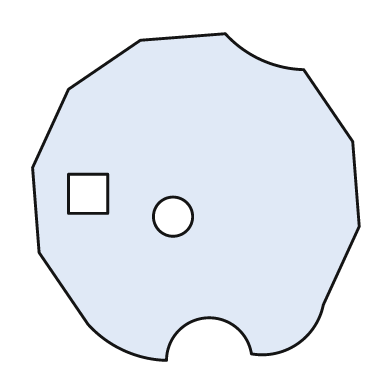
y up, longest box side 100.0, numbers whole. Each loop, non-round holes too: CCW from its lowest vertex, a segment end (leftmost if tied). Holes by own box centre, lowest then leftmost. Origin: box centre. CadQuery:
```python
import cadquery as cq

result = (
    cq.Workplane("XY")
    .moveTo(-9.0, -50.0)
    .threePointArc((3.0, -37.0), (17.0, -48.0))
    .threePointArc((31.0, -45.0), (39.0, -33.0))
    .lineTo(50.0, -9.0)
    .lineTo(48.0, 17.0)
    .lineTo(33.0, 39.0)
    .threePointArc((20.0, 42.0), (9.0, 50.0))
    .lineTo(-17.0, 48.0)
    .lineTo(-39.0, 33.0)
    .lineTo(-50.0, 9.0)
    .lineTo(-48.0, -17.0)
    .lineTo(-33.0, -39.0)
    .threePointArc((-22.0, -47.0), (-9.0, -50.0))
    .close()
    .moveTo(-7.0, -6.0)
    .circle(6.0)
    .moveTo(-39.0, -5.0)
    .lineTo(-27.0, -5.0)
    .lineTo(-27.0, 7.0)
    .lineTo(-39.0, 7.0)
    .close()
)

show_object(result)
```